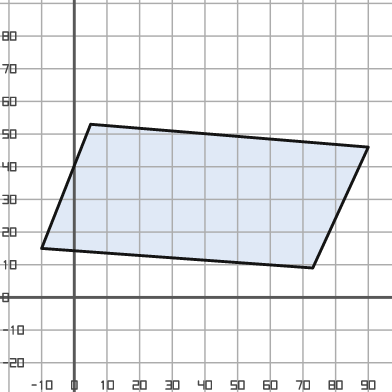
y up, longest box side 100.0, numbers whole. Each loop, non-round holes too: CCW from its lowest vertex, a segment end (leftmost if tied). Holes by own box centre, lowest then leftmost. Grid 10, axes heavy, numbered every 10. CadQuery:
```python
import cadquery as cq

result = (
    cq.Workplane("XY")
    .moveTo(73.0, 9.0)
    .lineTo(90.0, 46.0)
    .lineTo(5.0, 53.0)
    .lineTo(-10.0, 15.0)
    .close()
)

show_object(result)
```